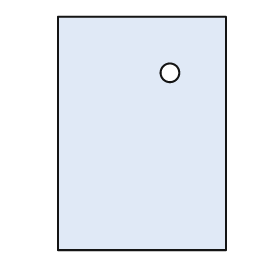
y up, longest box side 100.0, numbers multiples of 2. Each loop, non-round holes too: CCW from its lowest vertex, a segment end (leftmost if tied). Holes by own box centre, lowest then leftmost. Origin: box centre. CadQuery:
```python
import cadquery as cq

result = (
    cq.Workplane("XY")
    .moveTo(-36.0, -50.0)
    .lineTo(36.0, -50.0)
    .lineTo(36.0, 50.0)
    .lineTo(-36.0, 50.0)
    .close()
    .moveTo(12.0, 26.0)
    .circle(4.0)
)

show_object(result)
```